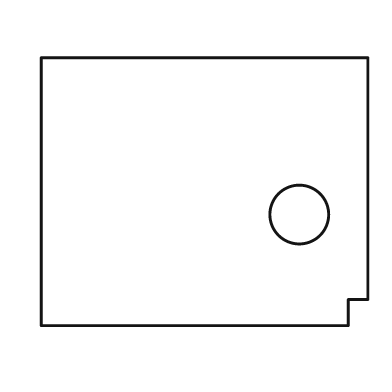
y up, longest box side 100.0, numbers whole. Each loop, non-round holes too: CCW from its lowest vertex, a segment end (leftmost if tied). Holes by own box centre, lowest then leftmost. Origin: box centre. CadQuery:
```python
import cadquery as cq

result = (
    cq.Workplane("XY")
    .moveTo(-50.0, -41.0)
    .lineTo(44.0, -41.0)
    .lineTo(44.0, -33.0)
    .lineTo(50.0, -33.0)
    .lineTo(50.0, 41.0)
    .lineTo(-50.0, 41.0)
    .close()
    .moveTo(29.0, -7.0)
    .circle(9.0)
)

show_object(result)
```